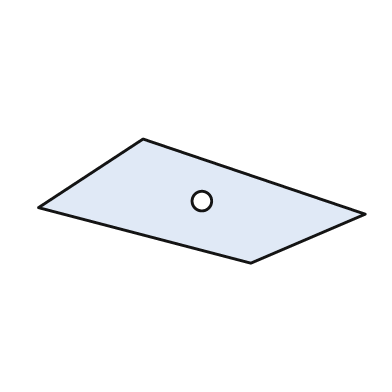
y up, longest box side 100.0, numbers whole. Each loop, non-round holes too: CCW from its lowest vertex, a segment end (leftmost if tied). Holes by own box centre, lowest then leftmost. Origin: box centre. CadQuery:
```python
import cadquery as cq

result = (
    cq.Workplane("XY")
    .moveTo(15.0, -19.0)
    .lineTo(50.0, -4.0)
    .lineTo(-18.0, 19.0)
    .lineTo(-50.0, -2.0)
    .close()
    .moveTo(0.0, 0.0)
    .circle(3.0)
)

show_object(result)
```